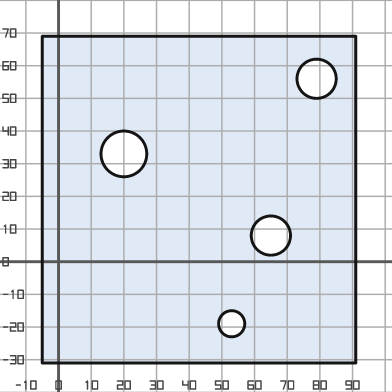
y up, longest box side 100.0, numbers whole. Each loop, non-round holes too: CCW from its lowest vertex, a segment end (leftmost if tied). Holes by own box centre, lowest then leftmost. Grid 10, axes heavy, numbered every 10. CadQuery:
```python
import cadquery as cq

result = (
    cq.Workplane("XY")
    .moveTo(-5.0, -31.0)
    .lineTo(91.0, -31.0)
    .lineTo(91.0, 69.0)
    .lineTo(-5.0, 69.0)
    .close()
    .moveTo(53.0, -19.0)
    .circle(4.0)
    .moveTo(65.0, 8.0)
    .circle(6.0)
    .moveTo(20.0, 33.0)
    .circle(7.0)
    .moveTo(79.0, 56.0)
    .circle(6.0)
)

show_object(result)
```